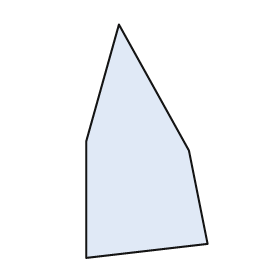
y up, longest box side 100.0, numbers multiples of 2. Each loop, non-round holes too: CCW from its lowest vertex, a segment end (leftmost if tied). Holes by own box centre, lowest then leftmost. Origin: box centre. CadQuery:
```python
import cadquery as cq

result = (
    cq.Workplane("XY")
    .moveTo(-26.0, -50.0)
    .lineTo(26.0, -44.0)
    .lineTo(18.0, -4.0)
    .lineTo(-12.0, 50.0)
    .lineTo(-26.0, 0.0)
    .close()
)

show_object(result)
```